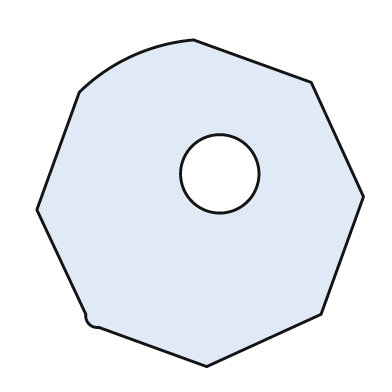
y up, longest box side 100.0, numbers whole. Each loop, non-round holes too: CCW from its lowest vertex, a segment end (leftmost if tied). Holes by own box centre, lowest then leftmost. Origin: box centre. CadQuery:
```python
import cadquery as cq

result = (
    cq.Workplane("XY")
    .moveTo(2.0, -50.0)
    .lineTo(37.0, -34.0)
    .lineTo(50.0, 2.0)
    .lineTo(34.0, 37.0)
    .lineTo(-2.0, 50.0)
    .threePointArc((-21.0, 45.0), (-37.0, 34.0))
    .lineTo(-50.0, -2.0)
    .lineTo(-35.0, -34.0)
    .threePointArc((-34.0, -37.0), (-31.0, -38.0))
    .close()
    .moveTo(6.0, 9.0)
    .circle(12.0)
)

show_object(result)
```